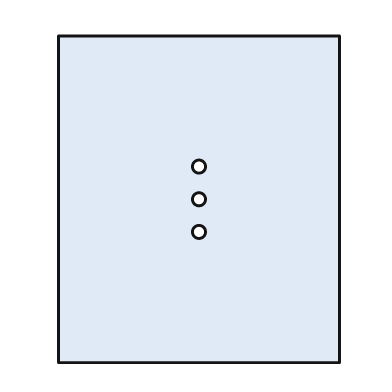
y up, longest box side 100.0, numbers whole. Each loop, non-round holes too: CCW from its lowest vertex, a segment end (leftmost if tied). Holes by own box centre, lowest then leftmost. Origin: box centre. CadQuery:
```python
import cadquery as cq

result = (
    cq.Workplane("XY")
    .moveTo(-43.0, -50.0)
    .lineTo(43.0, -50.0)
    .lineTo(43.0, 50.0)
    .lineTo(-43.0, 50.0)
    .close()
    .moveTo(0.0, -10.0)
    .circle(2.0)
    .moveTo(0.0, 0.0)
    .circle(2.0)
    .moveTo(0.0, 10.0)
    .circle(2.0)
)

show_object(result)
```